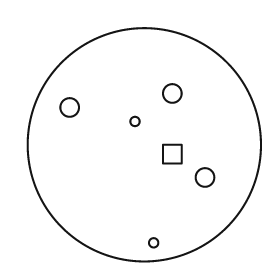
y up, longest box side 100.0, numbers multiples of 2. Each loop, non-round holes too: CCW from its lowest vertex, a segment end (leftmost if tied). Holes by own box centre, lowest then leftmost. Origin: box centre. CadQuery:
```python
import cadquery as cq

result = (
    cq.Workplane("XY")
    .moveTo(0.0, 0.0)
    .circle(50.0)
    .moveTo(4.0, -42.0)
    .circle(2.0)
    .moveTo(26.0, -14.0)
    .circle(4.0)
    .moveTo(8.0, -8.0)
    .lineTo(16.0, -8.0)
    .lineTo(16.0, 0.0)
    .lineTo(8.0, 0.0)
    .close()
    .moveTo(-4.0, 10.0)
    .circle(2.0)
    .moveTo(-32.0, 16.0)
    .circle(4.0)
    .moveTo(12.0, 22.0)
    .circle(4.0)
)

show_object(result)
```